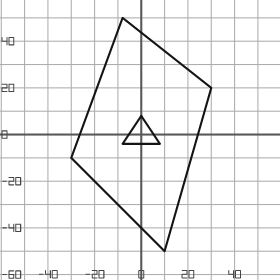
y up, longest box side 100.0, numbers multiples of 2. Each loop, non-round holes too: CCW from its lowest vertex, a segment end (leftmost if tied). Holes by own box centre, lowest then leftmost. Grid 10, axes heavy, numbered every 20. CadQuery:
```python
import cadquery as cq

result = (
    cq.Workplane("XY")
    .moveTo(10.0, -50.0)
    .lineTo(30.0, 20.0)
    .lineTo(-8.0, 50.0)
    .lineTo(-30.0, -10.0)
    .close()
    .moveTo(-8.0, -4.0)
    .lineTo(8.0, -4.0)
    .lineTo(0.0, 8.0)
    .close()
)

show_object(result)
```